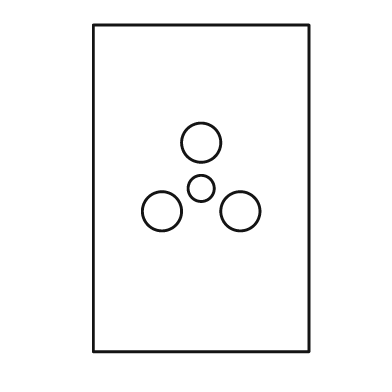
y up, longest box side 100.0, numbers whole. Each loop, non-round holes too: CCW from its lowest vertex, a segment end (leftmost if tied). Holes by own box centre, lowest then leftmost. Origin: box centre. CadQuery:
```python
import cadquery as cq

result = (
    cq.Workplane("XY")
    .moveTo(-33.0, -50.0)
    .lineTo(33.0, -50.0)
    .lineTo(33.0, 50.0)
    .lineTo(-33.0, 50.0)
    .close()
    .moveTo(-12.0, -7.0)
    .circle(6.0)
    .moveTo(12.0, -7.0)
    .circle(6.0)
    .moveTo(0.0, 0.0)
    .circle(4.0)
    .moveTo(0.0, 14.0)
    .circle(6.0)
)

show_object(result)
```